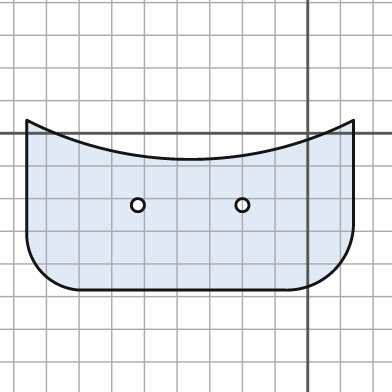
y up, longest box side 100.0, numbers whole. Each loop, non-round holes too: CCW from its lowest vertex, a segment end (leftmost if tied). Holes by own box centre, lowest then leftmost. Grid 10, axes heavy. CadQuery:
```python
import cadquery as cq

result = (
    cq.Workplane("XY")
    .moveTo(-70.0, -48.0)
    .lineTo(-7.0, -48.0)
    .threePointArc((8.0, -42.0), (14.0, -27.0))
    .lineTo(14.0, 4.0)
    .threePointArc((-36.0, -8.0), (-86.0, 4.0))
    .lineTo(-86.0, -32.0)
    .threePointArc((-81.0, -43.0), (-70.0, -48.0))
    .close()
    .moveTo(-52.0, -22.0)
    .circle(2.0)
    .moveTo(-20.0, -22.0)
    .circle(2.0)
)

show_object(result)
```